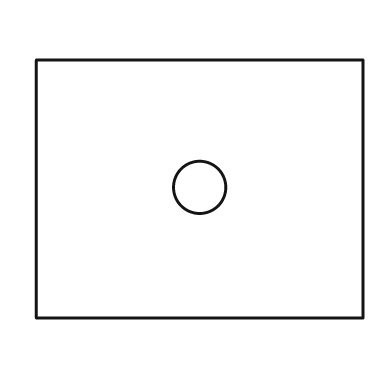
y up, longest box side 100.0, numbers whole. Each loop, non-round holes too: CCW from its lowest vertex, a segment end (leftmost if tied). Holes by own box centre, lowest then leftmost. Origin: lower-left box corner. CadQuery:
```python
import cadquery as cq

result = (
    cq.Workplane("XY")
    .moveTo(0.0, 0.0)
    .lineTo(100.0, 0.0)
    .lineTo(100.0, 79.0)
    .lineTo(0.0, 79.0)
    .close()
    .moveTo(50.0, 40.0)
    .circle(8.0)
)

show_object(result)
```